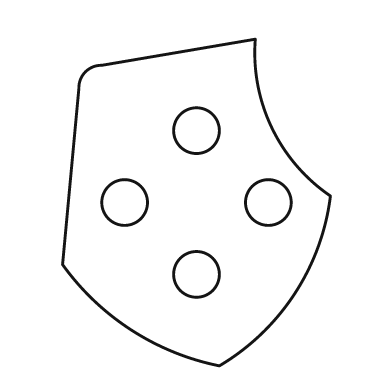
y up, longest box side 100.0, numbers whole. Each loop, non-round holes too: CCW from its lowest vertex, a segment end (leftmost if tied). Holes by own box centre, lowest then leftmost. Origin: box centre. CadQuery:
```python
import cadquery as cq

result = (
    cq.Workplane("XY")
    .moveTo(7.0, -50.0)
    .threePointArc((30.0, -28.0), (41.0, 2.0))
    .threePointArc((23.0, 23.0), (18.0, 50.0))
    .lineTo(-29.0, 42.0)
    .threePointArc((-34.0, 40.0), (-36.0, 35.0))
    .lineTo(-41.0, -19.0)
    .threePointArc((-20.0, -39.0), (7.0, -50.0))
    .close()
    .moveTo(0.0, -22.0)
    .circle(7.0)
    .moveTo(-22.0, 0.0)
    .circle(7.0)
    .moveTo(22.0, 0.0)
    .circle(7.0)
    .moveTo(0.0, 22.0)
    .circle(7.0)
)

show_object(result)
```